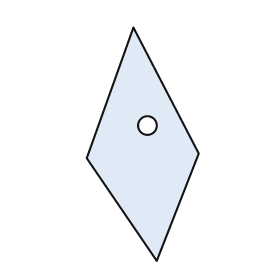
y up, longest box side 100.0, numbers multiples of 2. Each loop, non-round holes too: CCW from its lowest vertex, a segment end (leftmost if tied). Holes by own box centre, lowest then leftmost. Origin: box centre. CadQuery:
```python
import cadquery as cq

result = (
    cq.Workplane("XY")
    .moveTo(6.0, -50.0)
    .lineTo(24.0, -4.0)
    .lineTo(-4.0, 50.0)
    .lineTo(-24.0, -6.0)
    .close()
    .moveTo(2.0, 8.0)
    .circle(4.0)
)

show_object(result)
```